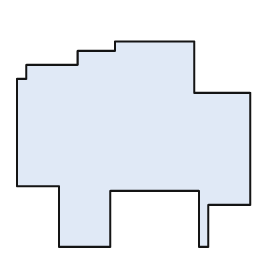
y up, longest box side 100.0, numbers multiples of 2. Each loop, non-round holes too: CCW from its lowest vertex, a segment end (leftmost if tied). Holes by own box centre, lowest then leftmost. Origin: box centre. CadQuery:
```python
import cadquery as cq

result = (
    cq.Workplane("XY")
    .moveTo(-32.0, -44.0)
    .lineTo(-10.0, -44.0)
    .lineTo(-10.0, -20.0)
    .lineTo(28.0, -20.0)
    .lineTo(28.0, -44.0)
    .lineTo(32.0, -44.0)
    .lineTo(32.0, -26.0)
    .lineTo(50.0, -26.0)
    .lineTo(50.0, 22.0)
    .lineTo(26.0, 22.0)
    .lineTo(26.0, 44.0)
    .lineTo(-8.0, 44.0)
    .lineTo(-8.0, 40.0)
    .lineTo(-24.0, 40.0)
    .lineTo(-24.0, 34.0)
    .lineTo(-46.0, 34.0)
    .lineTo(-46.0, 28.0)
    .lineTo(-50.0, 28.0)
    .lineTo(-50.0, -18.0)
    .lineTo(-32.0, -18.0)
    .close()
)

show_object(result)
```